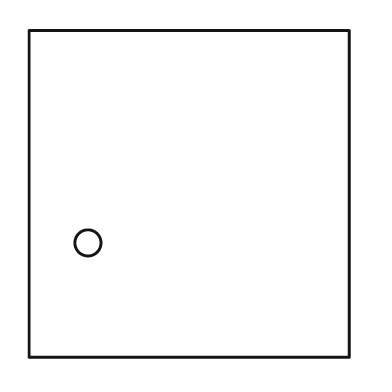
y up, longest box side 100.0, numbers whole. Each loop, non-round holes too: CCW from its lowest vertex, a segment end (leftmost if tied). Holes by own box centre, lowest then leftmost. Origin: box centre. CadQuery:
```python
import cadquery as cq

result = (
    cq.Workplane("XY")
    .moveTo(-49.0, -50.0)
    .lineTo(49.0, -50.0)
    .lineTo(49.0, 50.0)
    .lineTo(-49.0, 50.0)
    .close()
    .moveTo(-31.0, -15.0)
    .circle(4.0)
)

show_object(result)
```